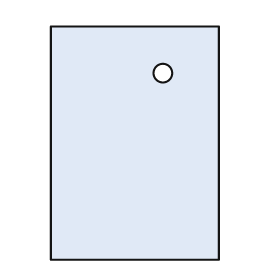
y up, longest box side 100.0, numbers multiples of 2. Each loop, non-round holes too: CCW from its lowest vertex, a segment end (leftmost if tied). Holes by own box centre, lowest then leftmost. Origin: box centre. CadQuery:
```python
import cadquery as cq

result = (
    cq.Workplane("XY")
    .moveTo(-36.0, -50.0)
    .lineTo(36.0, -50.0)
    .lineTo(36.0, 50.0)
    .lineTo(-36.0, 50.0)
    .close()
    .moveTo(12.0, 30.0)
    .circle(4.0)
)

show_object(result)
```